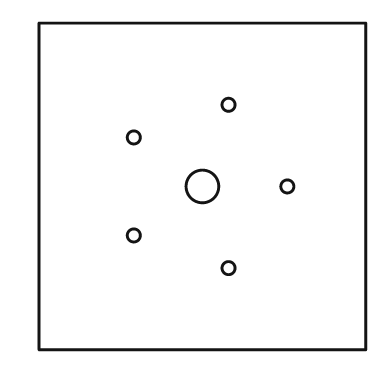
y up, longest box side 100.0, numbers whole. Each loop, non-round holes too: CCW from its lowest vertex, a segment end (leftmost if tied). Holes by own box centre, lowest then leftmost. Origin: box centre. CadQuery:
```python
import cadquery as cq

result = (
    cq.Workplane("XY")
    .moveTo(-50.0, -50.0)
    .lineTo(50.0, -50.0)
    .lineTo(50.0, 50.0)
    .lineTo(-50.0, 50.0)
    .close()
    .moveTo(8.0, -25.0)
    .circle(2.0)
    .moveTo(-21.0, -15.0)
    .circle(2.0)
    .moveTo(0.0, 0.0)
    .circle(5.0)
    .moveTo(26.0, 0.0)
    .circle(2.0)
    .moveTo(-21.0, 15.0)
    .circle(2.0)
    .moveTo(8.0, 25.0)
    .circle(2.0)
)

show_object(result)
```